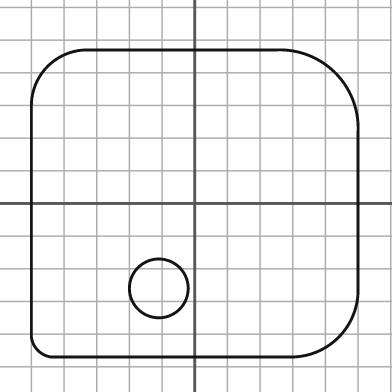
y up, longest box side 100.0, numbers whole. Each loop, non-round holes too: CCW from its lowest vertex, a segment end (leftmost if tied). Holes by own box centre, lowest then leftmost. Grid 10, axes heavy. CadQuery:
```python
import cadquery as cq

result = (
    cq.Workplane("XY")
    .moveTo(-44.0, -47.0)
    .lineTo(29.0, -47.0)
    .threePointArc((44.0, -41.0), (50.0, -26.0))
    .lineTo(50.0, 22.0)
    .threePointArc((43.0, 40.0), (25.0, 47.0))
    .lineTo(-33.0, 47.0)
    .threePointArc((-45.0, 42.0), (-50.0, 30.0))
    .lineTo(-50.0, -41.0)
    .threePointArc((-48.0, -45.0), (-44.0, -47.0))
    .close()
    .moveTo(-11.0, -26.0)
    .circle(9.0)
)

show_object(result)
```